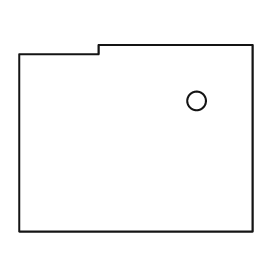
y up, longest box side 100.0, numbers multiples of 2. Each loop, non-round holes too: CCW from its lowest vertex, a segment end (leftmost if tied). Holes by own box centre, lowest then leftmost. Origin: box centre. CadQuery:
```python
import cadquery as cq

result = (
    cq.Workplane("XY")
    .moveTo(-50.0, -40.0)
    .lineTo(50.0, -40.0)
    .lineTo(50.0, 40.0)
    .lineTo(-16.0, 40.0)
    .lineTo(-16.0, 36.0)
    .lineTo(-50.0, 36.0)
    .close()
    .moveTo(26.0, 16.0)
    .circle(4.0)
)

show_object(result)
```